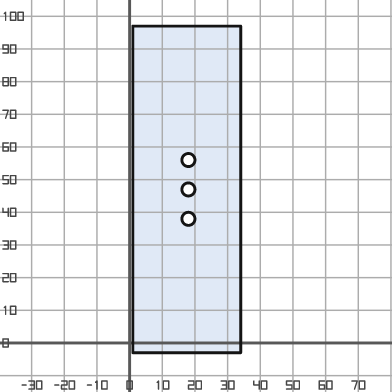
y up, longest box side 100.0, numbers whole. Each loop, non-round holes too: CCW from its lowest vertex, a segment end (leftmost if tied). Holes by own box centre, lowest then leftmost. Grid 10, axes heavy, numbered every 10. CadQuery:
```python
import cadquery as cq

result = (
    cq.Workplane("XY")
    .moveTo(1.0, -3.0)
    .lineTo(34.0, -3.0)
    .lineTo(34.0, 97.0)
    .lineTo(1.0, 97.0)
    .close()
    .moveTo(18.0, 38.0)
    .circle(2.0)
    .moveTo(18.0, 47.0)
    .circle(2.0)
    .moveTo(18.0, 56.0)
    .circle(2.0)
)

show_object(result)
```